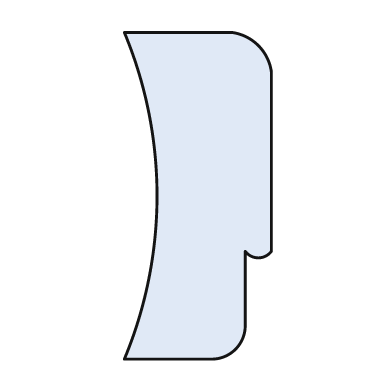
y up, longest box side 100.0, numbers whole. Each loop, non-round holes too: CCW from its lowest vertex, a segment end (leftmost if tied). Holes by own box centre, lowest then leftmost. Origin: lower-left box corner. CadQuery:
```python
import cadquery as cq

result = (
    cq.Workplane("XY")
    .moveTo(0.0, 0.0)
    .lineTo(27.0, 0.0)
    .threePointArc((34.0, 3.0), (37.0, 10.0))
    .lineTo(37.0, 33.0)
    .threePointArc((41.0, 31.0), (45.0, 33.0))
    .lineTo(45.0, 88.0)
    .threePointArc((41.0, 96.0), (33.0, 100.0))
    .lineTo(0.0, 100.0)
    .threePointArc((10.0, 50.0), (0.0, 0.0))
    .close()
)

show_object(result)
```